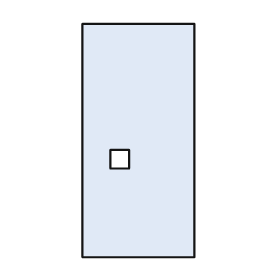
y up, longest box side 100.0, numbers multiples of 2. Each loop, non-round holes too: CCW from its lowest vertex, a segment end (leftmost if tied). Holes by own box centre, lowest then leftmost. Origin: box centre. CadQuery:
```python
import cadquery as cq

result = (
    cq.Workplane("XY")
    .moveTo(-24.0, -50.0)
    .lineTo(24.0, -50.0)
    .lineTo(24.0, 50.0)
    .lineTo(-24.0, 50.0)
    .close()
    .moveTo(-12.0, -12.0)
    .lineTo(-4.0, -12.0)
    .lineTo(-4.0, -4.0)
    .lineTo(-12.0, -4.0)
    .close()
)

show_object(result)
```